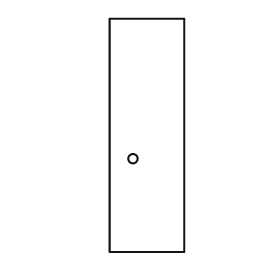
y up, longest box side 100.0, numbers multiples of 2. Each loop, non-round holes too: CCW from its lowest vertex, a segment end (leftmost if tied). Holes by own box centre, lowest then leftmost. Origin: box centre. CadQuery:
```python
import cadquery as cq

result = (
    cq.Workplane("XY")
    .moveTo(-16.0, -50.0)
    .lineTo(16.0, -50.0)
    .lineTo(16.0, 50.0)
    .lineTo(-16.0, 50.0)
    .close()
    .moveTo(-6.0, -10.0)
    .circle(2.0)
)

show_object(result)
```